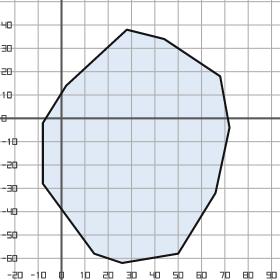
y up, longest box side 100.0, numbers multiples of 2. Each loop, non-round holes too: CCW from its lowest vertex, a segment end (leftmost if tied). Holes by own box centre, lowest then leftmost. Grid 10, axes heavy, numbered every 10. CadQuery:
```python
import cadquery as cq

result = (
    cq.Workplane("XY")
    .moveTo(26.0, -62.0)
    .lineTo(50.0, -58.0)
    .lineTo(66.0, -32.0)
    .lineTo(72.0, -4.0)
    .lineTo(68.0, 18.0)
    .lineTo(44.0, 34.0)
    .lineTo(28.0, 38.0)
    .lineTo(2.0, 14.0)
    .lineTo(-8.0, -2.0)
    .lineTo(-8.0, -28.0)
    .lineTo(14.0, -58.0)
    .close()
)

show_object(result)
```